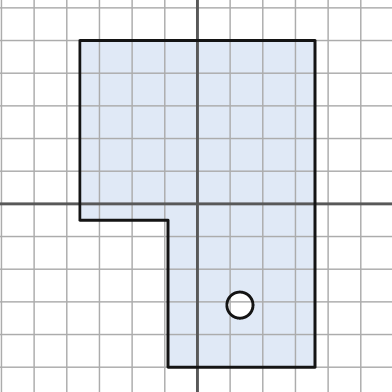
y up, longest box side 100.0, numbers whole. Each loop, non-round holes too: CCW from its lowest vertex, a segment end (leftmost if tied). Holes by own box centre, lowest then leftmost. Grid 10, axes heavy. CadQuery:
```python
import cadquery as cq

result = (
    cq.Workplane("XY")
    .moveTo(-9.0, -50.0)
    .lineTo(36.0, -50.0)
    .lineTo(36.0, 50.0)
    .lineTo(-36.0, 50.0)
    .lineTo(-36.0, -5.0)
    .lineTo(-9.0, -5.0)
    .close()
    .moveTo(13.0, -31.0)
    .circle(4.0)
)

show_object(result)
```